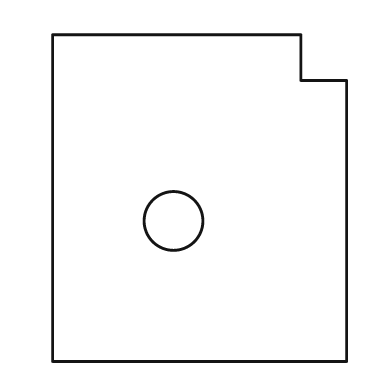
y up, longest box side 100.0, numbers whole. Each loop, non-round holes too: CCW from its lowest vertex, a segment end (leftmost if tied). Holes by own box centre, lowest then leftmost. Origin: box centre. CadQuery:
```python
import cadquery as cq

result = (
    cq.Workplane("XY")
    .moveTo(-45.0, -50.0)
    .lineTo(45.0, -50.0)
    .lineTo(45.0, 36.0)
    .lineTo(31.0, 36.0)
    .lineTo(31.0, 50.0)
    .lineTo(-45.0, 50.0)
    .close()
    .moveTo(-8.0, -7.0)
    .circle(9.0)
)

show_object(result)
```